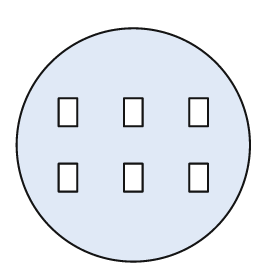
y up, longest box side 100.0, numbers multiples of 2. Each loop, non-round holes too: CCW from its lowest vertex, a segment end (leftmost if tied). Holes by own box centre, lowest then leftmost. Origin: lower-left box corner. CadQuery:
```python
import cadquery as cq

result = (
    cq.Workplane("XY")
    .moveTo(50.0, 50.0)
    .circle(50.0)
    .moveTo(18.0, 30.0)
    .lineTo(26.0, 30.0)
    .lineTo(26.0, 42.0)
    .lineTo(18.0, 42.0)
    .close()
    .moveTo(46.0, 30.0)
    .lineTo(54.0, 30.0)
    .lineTo(54.0, 42.0)
    .lineTo(46.0, 42.0)
    .close()
    .moveTo(74.0, 30.0)
    .lineTo(82.0, 30.0)
    .lineTo(82.0, 42.0)
    .lineTo(74.0, 42.0)
    .close()
    .moveTo(18.0, 58.0)
    .lineTo(26.0, 58.0)
    .lineTo(26.0, 70.0)
    .lineTo(18.0, 70.0)
    .close()
    .moveTo(46.0, 58.0)
    .lineTo(54.0, 58.0)
    .lineTo(54.0, 70.0)
    .lineTo(46.0, 70.0)
    .close()
    .moveTo(74.0, 58.0)
    .lineTo(82.0, 58.0)
    .lineTo(82.0, 70.0)
    .lineTo(74.0, 70.0)
    .close()
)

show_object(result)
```